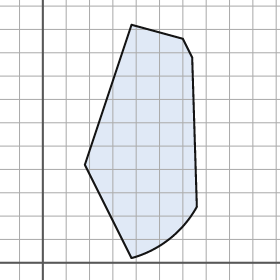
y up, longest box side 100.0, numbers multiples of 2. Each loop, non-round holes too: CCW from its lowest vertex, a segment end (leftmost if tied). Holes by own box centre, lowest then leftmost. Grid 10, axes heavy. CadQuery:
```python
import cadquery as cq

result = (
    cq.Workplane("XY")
    .moveTo(38.0, 2.0)
    .threePointArc((54.0, 10.0), (66.0, 24.0))
    .lineTo(64.0, 88.0)
    .lineTo(60.0, 96.0)
    .lineTo(38.0, 102.0)
    .lineTo(18.0, 42.0)
    .close()
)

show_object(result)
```